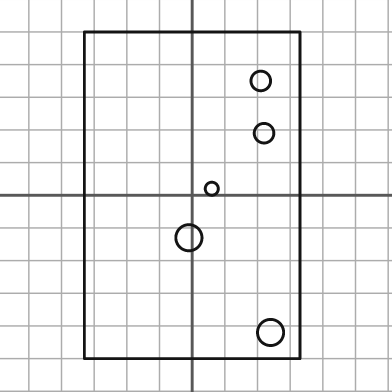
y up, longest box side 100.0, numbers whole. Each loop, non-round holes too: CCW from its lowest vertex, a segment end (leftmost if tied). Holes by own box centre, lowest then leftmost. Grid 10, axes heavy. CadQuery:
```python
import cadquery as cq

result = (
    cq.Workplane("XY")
    .moveTo(-33.0, -50.0)
    .lineTo(33.0, -50.0)
    .lineTo(33.0, 50.0)
    .lineTo(-33.0, 50.0)
    .close()
    .moveTo(24.0, -42.0)
    .circle(4.0)
    .moveTo(-1.0, -13.0)
    .circle(4.0)
    .moveTo(6.0, 2.0)
    .circle(2.0)
    .moveTo(22.0, 19.0)
    .circle(3.0)
    .moveTo(21.0, 35.0)
    .circle(3.0)
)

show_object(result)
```